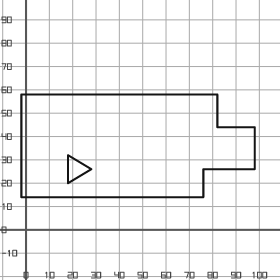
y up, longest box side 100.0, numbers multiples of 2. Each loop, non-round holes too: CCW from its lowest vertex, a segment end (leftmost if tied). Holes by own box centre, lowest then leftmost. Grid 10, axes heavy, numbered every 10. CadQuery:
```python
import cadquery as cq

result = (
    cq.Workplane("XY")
    .moveTo(-2.0, 14.0)
    .lineTo(76.0, 14.0)
    .lineTo(76.0, 26.0)
    .lineTo(98.0, 26.0)
    .lineTo(98.0, 44.0)
    .lineTo(82.0, 44.0)
    .lineTo(82.0, 58.0)
    .lineTo(-2.0, 58.0)
    .close()
    .moveTo(18.0, 20.0)
    .lineTo(28.0, 26.0)
    .lineTo(18.0, 32.0)
    .close()
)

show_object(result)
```